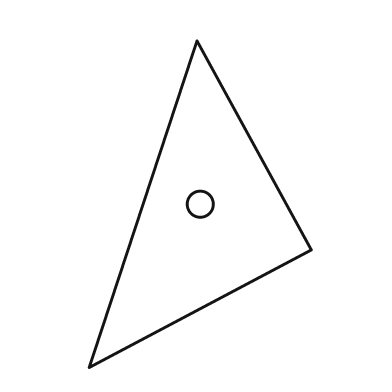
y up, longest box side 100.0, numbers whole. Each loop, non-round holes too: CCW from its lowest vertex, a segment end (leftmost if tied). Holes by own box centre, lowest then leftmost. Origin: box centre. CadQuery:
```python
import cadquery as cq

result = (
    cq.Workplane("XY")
    .moveTo(-34.0, -50.0)
    .lineTo(34.0, -14.0)
    .lineTo(-1.0, 50.0)
    .close()
    .moveTo(0.0, 0.0)
    .circle(4.0)
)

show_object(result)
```